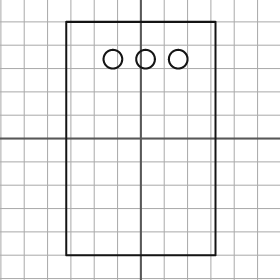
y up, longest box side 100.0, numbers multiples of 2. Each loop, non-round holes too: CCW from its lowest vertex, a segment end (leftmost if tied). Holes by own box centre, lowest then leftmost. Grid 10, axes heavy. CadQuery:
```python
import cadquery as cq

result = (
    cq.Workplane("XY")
    .moveTo(-32.0, -50.0)
    .lineTo(32.0, -50.0)
    .lineTo(32.0, 50.0)
    .lineTo(-32.0, 50.0)
    .close()
    .moveTo(-12.0, 34.0)
    .circle(4.0)
    .moveTo(2.0, 34.0)
    .circle(4.0)
    .moveTo(16.0, 34.0)
    .circle(4.0)
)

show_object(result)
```